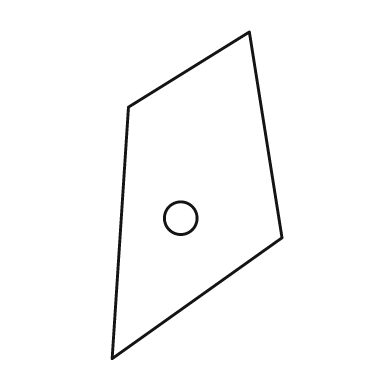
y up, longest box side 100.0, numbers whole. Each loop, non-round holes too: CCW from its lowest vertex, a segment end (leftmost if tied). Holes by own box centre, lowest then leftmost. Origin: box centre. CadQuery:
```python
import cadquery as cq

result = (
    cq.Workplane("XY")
    .moveTo(-26.0, -50.0)
    .lineTo(26.0, -13.0)
    .lineTo(16.0, 50.0)
    .lineTo(-21.0, 27.0)
    .close()
    .moveTo(-5.0, -7.0)
    .circle(5.0)
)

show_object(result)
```